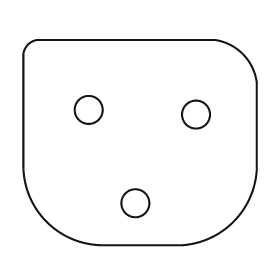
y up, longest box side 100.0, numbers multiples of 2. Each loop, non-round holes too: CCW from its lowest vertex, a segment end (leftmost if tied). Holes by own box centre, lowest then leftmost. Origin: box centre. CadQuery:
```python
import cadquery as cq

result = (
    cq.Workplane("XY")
    .moveTo(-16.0, -44.0)
    .lineTo(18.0, -44.0)
    .threePointArc((40.0, -34.0), (50.0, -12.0))
    .lineTo(50.0, 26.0)
    .threePointArc((44.0, 38.0), (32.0, 44.0))
    .lineTo(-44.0, 44.0)
    .threePointArc((-48.0, 42.0), (-50.0, 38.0))
    .lineTo(-50.0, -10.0)
    .threePointArc((-40.0, -34.0), (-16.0, -44.0))
    .close()
    .moveTo(-2.0, -26.0)
    .circle(6.0)
    .moveTo(24.0, 12.0)
    .circle(6.0)
    .moveTo(-22.0, 14.0)
    .circle(6.0)
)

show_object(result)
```